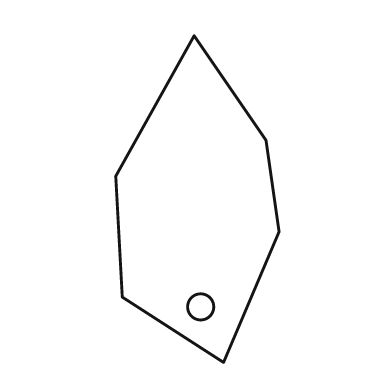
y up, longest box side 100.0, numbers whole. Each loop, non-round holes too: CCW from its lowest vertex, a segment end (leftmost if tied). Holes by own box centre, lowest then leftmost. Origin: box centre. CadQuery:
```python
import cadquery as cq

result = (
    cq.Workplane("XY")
    .moveTo(8.0, -50.0)
    .lineTo(25.0, -10.0)
    .lineTo(21.0, 18.0)
    .lineTo(-1.0, 50.0)
    .lineTo(-25.0, 7.0)
    .lineTo(-23.0, -30.0)
    .close()
    .moveTo(1.0, -33.0)
    .circle(4.0)
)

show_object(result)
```